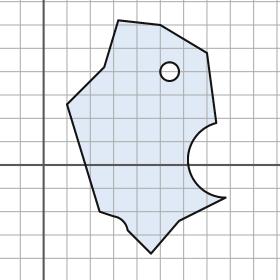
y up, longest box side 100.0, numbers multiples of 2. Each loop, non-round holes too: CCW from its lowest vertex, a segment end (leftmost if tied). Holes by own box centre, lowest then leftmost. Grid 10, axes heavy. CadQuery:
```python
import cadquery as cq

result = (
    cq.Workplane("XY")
    .moveTo(46.0, -38.0)
    .lineTo(58.0, -24.0)
    .lineTo(78.0, -14.0)
    .threePointArc((62.0, 0.0), (74.0, 18.0))
    .lineTo(70.0, 48.0)
    .lineTo(50.0, 60.0)
    .lineTo(32.0, 62.0)
    .lineTo(26.0, 42.0)
    .lineTo(10.0, 26.0)
    .lineTo(24.0, -20.0)
    .lineTo(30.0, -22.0)
    .threePointArc((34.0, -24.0), (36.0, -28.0))
    .close()
    .moveTo(54.0, 40.0)
    .circle(4.0)
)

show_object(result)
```